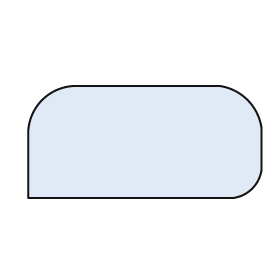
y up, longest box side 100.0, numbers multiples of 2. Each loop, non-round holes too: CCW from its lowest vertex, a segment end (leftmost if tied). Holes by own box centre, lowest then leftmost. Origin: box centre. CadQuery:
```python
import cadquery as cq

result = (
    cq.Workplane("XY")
    .moveTo(-50.0, -24.0)
    .lineTo(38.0, -24.0)
    .threePointArc((46.0, -20.0), (50.0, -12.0))
    .lineTo(50.0, 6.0)
    .threePointArc((44.0, 18.0), (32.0, 24.0))
    .lineTo(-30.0, 24.0)
    .threePointArc((-44.0, 18.0), (-50.0, 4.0))
    .close()
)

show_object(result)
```